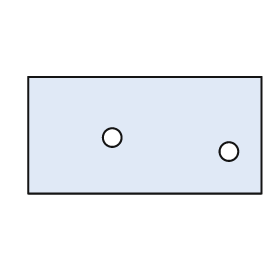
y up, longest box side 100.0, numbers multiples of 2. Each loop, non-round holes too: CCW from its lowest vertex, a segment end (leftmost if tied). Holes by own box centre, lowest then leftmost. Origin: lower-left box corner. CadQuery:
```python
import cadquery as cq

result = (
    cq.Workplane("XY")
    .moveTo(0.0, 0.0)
    .lineTo(100.0, 0.0)
    .lineTo(100.0, 50.0)
    .lineTo(0.0, 50.0)
    .close()
    .moveTo(86.0, 18.0)
    .circle(4.0)
    .moveTo(36.0, 24.0)
    .circle(4.0)
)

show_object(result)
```